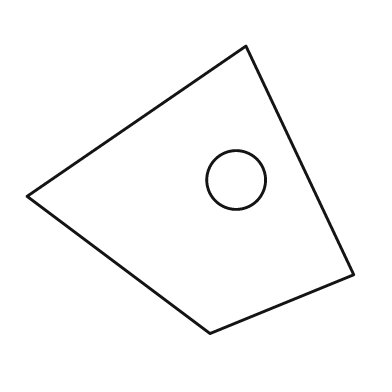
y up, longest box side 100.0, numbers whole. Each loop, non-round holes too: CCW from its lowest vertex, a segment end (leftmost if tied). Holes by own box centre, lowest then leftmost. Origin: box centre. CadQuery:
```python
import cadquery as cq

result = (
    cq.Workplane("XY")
    .moveTo(6.0, -44.0)
    .lineTo(50.0, -26.0)
    .lineTo(17.0, 44.0)
    .lineTo(-50.0, -2.0)
    .close()
    .moveTo(14.0, 3.0)
    .circle(9.0)
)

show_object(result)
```